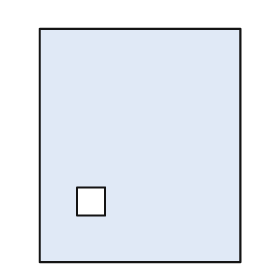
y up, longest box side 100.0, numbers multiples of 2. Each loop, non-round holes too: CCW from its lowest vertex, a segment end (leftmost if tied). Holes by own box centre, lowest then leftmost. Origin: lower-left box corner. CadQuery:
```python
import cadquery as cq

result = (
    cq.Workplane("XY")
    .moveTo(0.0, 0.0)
    .lineTo(86.0, 0.0)
    .lineTo(86.0, 100.0)
    .lineTo(0.0, 100.0)
    .close()
    .moveTo(16.0, 20.0)
    .lineTo(28.0, 20.0)
    .lineTo(28.0, 32.0)
    .lineTo(16.0, 32.0)
    .close()
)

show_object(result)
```